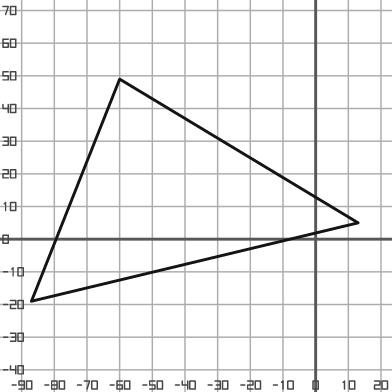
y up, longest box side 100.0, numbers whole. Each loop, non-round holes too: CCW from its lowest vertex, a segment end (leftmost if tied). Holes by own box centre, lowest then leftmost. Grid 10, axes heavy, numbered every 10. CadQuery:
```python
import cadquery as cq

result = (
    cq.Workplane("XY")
    .moveTo(-87.0, -19.0)
    .lineTo(13.0, 5.0)
    .lineTo(-60.0, 49.0)
    .close()
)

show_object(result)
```